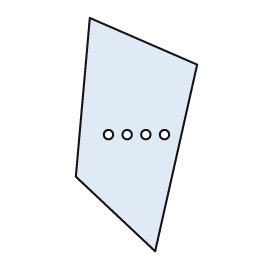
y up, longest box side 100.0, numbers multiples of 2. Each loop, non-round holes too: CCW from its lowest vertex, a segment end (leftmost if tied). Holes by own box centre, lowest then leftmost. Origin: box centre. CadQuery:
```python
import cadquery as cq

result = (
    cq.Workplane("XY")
    .moveTo(8.0, -50.0)
    .lineTo(26.0, 30.0)
    .lineTo(-20.0, 50.0)
    .lineTo(-26.0, -18.0)
    .close()
    .moveTo(-12.0, 0.0)
    .circle(2.0)
    .moveTo(-4.0, 0.0)
    .circle(2.0)
    .moveTo(4.0, 0.0)
    .circle(2.0)
    .moveTo(12.0, 0.0)
    .circle(2.0)
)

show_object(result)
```